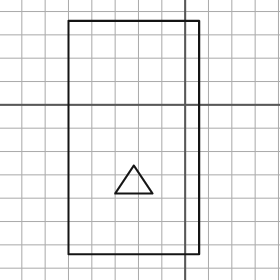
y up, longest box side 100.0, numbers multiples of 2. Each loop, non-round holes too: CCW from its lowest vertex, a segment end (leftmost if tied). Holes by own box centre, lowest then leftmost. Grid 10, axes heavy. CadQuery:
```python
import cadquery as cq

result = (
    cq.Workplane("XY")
    .moveTo(-50.0, -64.0)
    .lineTo(6.0, -64.0)
    .lineTo(6.0, 36.0)
    .lineTo(-50.0, 36.0)
    .close()
    .moveTo(-30.0, -38.0)
    .lineTo(-14.0, -38.0)
    .lineTo(-22.0, -26.0)
    .close()
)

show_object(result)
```